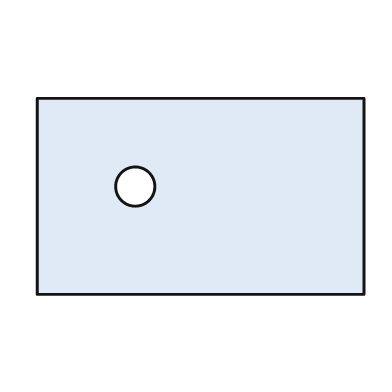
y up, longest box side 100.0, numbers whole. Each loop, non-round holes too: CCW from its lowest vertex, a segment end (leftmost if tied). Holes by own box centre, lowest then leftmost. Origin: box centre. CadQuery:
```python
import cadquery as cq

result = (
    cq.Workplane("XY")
    .moveTo(-50.0, -30.0)
    .lineTo(50.0, -30.0)
    .lineTo(50.0, 30.0)
    .lineTo(-50.0, 30.0)
    .close()
    .moveTo(-20.0, 3.0)
    .circle(6.0)
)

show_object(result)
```